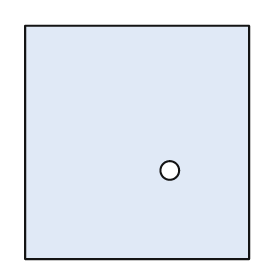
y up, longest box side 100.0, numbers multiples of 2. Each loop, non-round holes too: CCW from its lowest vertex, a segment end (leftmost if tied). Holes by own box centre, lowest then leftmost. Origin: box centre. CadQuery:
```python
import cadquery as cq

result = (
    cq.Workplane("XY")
    .moveTo(-48.0, -50.0)
    .lineTo(48.0, -50.0)
    .lineTo(48.0, 50.0)
    .lineTo(-48.0, 50.0)
    .close()
    .moveTo(14.0, -12.0)
    .circle(4.0)
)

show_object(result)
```